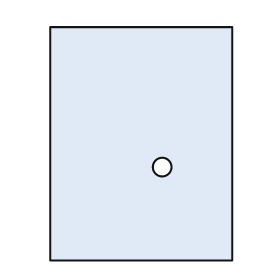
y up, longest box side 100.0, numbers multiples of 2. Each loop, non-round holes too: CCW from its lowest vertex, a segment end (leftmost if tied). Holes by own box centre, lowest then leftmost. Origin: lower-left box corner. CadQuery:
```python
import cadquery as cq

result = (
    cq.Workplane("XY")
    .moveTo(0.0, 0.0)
    .lineTo(78.0, 0.0)
    .lineTo(78.0, 100.0)
    .lineTo(0.0, 100.0)
    .close()
    .moveTo(48.0, 40.0)
    .circle(4.0)
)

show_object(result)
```